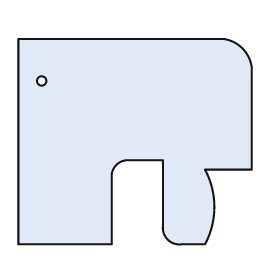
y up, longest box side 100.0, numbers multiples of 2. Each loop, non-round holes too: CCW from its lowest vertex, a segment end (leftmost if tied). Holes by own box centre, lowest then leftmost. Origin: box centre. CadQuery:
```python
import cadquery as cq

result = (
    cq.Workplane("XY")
    .moveTo(-50.0, -44.0)
    .lineTo(-10.0, -44.0)
    .lineTo(-10.0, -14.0)
    .threePointArc((-8.0, -10.0), (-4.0, -8.0))
    .lineTo(12.0, -8.0)
    .lineTo(12.0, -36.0)
    .threePointArc((14.0, -42.0), (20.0, -44.0))
    .lineTo(30.0, -44.0)
    .threePointArc((34.0, -28.0), (30.0, -12.0))
    .lineTo(50.0, -12.0)
    .lineTo(50.0, 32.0)
    .threePointArc((46.0, 40.0), (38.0, 44.0))
    .lineTo(-50.0, 44.0)
    .close()
    .moveTo(-40.0, 26.0)
    .circle(2.0)
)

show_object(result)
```